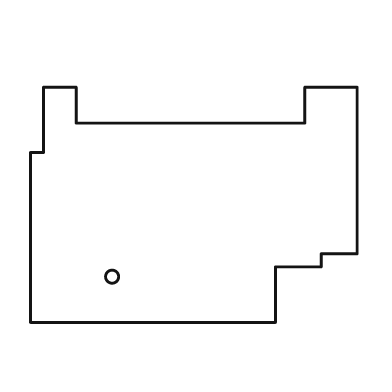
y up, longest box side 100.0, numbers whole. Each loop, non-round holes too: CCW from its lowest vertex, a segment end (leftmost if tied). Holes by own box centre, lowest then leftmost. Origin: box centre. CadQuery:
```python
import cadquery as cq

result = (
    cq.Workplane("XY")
    .moveTo(-50.0, -36.0)
    .lineTo(25.0, -36.0)
    .lineTo(25.0, -19.0)
    .lineTo(39.0, -19.0)
    .lineTo(39.0, -15.0)
    .lineTo(50.0, -15.0)
    .lineTo(50.0, 36.0)
    .lineTo(34.0, 36.0)
    .lineTo(34.0, 25.0)
    .lineTo(-36.0, 25.0)
    .lineTo(-36.0, 36.0)
    .lineTo(-46.0, 36.0)
    .lineTo(-46.0, 16.0)
    .lineTo(-50.0, 16.0)
    .close()
    .moveTo(-25.0, -22.0)
    .circle(2.0)
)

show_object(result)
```